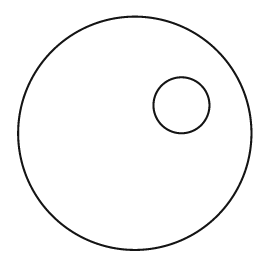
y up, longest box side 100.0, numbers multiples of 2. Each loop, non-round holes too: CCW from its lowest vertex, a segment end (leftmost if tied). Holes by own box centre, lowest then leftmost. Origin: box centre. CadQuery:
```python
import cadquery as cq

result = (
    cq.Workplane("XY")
    .moveTo(0.0, 0.0)
    .circle(50.0)
    .moveTo(20.0, 12.0)
    .circle(12.0)
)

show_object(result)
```